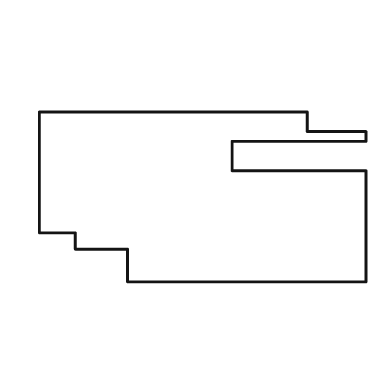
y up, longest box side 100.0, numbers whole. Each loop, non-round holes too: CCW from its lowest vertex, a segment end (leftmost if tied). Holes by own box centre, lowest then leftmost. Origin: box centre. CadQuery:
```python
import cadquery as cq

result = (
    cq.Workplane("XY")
    .moveTo(-23.0, -26.0)
    .lineTo(50.0, -26.0)
    .lineTo(50.0, 8.0)
    .lineTo(9.0, 8.0)
    .lineTo(9.0, 17.0)
    .lineTo(50.0, 17.0)
    .lineTo(50.0, 20.0)
    .lineTo(32.0, 20.0)
    .lineTo(32.0, 26.0)
    .lineTo(-50.0, 26.0)
    .lineTo(-50.0, -11.0)
    .lineTo(-39.0, -11.0)
    .lineTo(-39.0, -16.0)
    .lineTo(-23.0, -16.0)
    .close()
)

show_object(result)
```